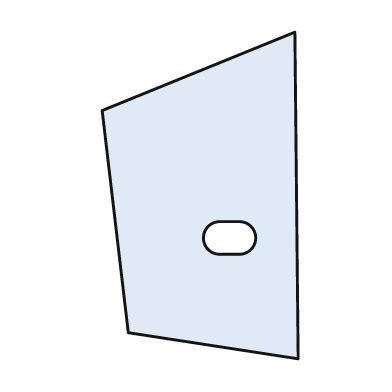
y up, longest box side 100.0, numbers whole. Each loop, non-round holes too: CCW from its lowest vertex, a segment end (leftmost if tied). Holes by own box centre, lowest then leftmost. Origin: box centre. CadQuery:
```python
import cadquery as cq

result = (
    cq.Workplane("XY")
    .moveTo(30.0, -50.0)
    .lineTo(29.0, 50.0)
    .lineTo(-30.0, 26.0)
    .lineTo(-22.0, -42.0)
    .close()
    .moveTo(6.0, -18.0)
    .lineTo(12.0, -18.0)
    .threePointArc((17.0, -13.0), (12.0, -8.0))
    .lineTo(6.0, -8.0)
    .threePointArc((1.0, -13.0), (6.0, -18.0))
    .close()
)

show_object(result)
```